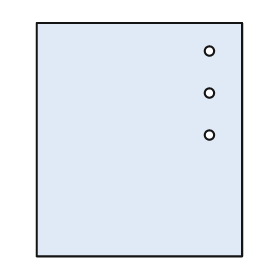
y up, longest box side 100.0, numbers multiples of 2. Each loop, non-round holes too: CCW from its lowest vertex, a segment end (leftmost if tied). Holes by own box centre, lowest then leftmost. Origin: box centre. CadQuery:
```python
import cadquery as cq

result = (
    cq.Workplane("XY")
    .moveTo(-44.0, -50.0)
    .lineTo(44.0, -50.0)
    .lineTo(44.0, 50.0)
    .lineTo(-44.0, 50.0)
    .close()
    .moveTo(30.0, 2.0)
    .circle(2.0)
    .moveTo(30.0, 20.0)
    .circle(2.0)
    .moveTo(30.0, 38.0)
    .circle(2.0)
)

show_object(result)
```